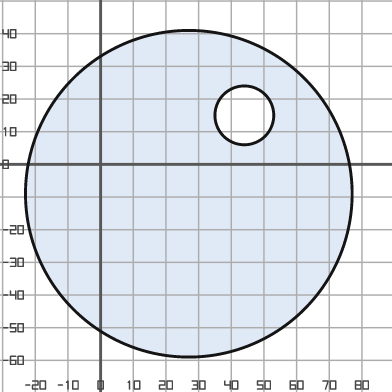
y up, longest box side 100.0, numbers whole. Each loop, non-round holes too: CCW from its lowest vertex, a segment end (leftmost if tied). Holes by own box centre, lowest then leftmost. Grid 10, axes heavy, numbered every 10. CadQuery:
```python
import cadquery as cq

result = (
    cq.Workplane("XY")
    .moveTo(27.0, -9.0)
    .circle(50.0)
    .moveTo(44.0, 15.0)
    .circle(9.0)
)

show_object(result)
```